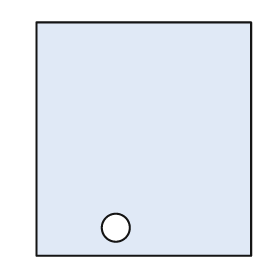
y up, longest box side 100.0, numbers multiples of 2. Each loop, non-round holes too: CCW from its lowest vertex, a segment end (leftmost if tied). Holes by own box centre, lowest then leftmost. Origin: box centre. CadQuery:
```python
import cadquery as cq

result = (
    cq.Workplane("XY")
    .moveTo(-46.0, -50.0)
    .lineTo(46.0, -50.0)
    .lineTo(46.0, 50.0)
    .lineTo(-46.0, 50.0)
    .close()
    .moveTo(-12.0, -38.0)
    .circle(6.0)
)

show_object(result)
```